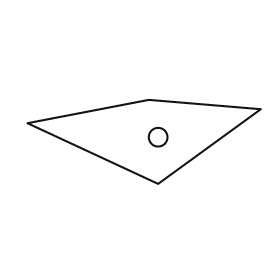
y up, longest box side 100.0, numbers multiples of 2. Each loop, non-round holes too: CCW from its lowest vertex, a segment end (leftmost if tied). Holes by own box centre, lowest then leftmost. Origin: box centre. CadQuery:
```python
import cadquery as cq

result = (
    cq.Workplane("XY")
    .moveTo(6.0, -18.0)
    .lineTo(50.0, 14.0)
    .lineTo(2.0, 18.0)
    .lineTo(-50.0, 8.0)
    .close()
    .moveTo(6.0, 2.0)
    .circle(4.0)
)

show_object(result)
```